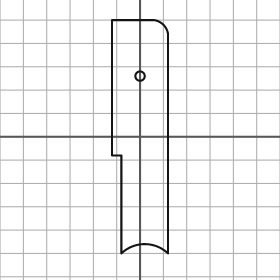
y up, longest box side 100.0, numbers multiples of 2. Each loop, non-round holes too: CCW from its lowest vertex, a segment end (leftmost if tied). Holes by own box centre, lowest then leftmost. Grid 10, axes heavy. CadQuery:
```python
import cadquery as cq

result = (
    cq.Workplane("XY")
    .moveTo(-8.0, -50.0)
    .threePointArc((2.0, -46.0), (12.0, -50.0))
    .lineTo(12.0, 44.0)
    .threePointArc((10.0, 48.0), (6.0, 50.0))
    .lineTo(-12.0, 50.0)
    .lineTo(-12.0, -8.0)
    .lineTo(-8.0, -8.0)
    .close()
    .moveTo(0.0, 26.0)
    .circle(2.0)
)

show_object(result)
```